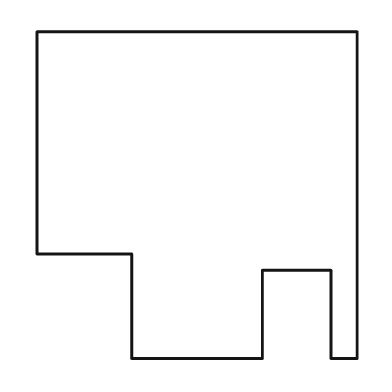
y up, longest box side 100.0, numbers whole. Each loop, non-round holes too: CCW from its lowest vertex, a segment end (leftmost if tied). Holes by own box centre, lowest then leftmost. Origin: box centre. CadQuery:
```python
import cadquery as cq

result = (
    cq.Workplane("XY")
    .moveTo(-20.0, -50.0)
    .lineTo(20.0, -50.0)
    .lineTo(20.0, -23.0)
    .lineTo(41.0, -23.0)
    .lineTo(41.0, -50.0)
    .lineTo(49.0, -50.0)
    .lineTo(49.0, 50.0)
    .lineTo(-49.0, 50.0)
    .lineTo(-49.0, -18.0)
    .lineTo(-20.0, -18.0)
    .close()
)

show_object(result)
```